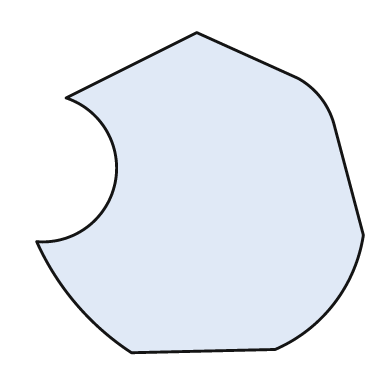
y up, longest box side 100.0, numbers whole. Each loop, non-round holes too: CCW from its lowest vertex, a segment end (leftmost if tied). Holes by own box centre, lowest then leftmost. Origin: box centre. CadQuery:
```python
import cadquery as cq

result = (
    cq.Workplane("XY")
    .moveTo(-21.0, -49.0)
    .lineTo(23.0, -48.0)
    .threePointArc((41.0, -34.0), (50.0, -13.0))
    .lineTo(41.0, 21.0)
    .threePointArc((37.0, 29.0), (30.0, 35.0))
    .lineTo(-1.0, 49.0)
    .lineTo(-41.0, 29.0)
    .threePointArc((-26.0, 3.0), (-50.0, -15.0))
    .threePointArc((-38.0, -34.0), (-21.0, -49.0))
    .close()
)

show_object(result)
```